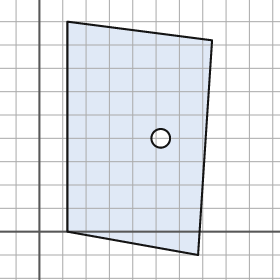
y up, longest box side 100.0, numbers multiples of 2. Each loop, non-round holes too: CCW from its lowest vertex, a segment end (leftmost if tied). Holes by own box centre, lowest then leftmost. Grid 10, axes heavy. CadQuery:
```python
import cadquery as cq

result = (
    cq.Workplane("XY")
    .moveTo(68.0, -10.0)
    .lineTo(74.0, 82.0)
    .lineTo(12.0, 90.0)
    .lineTo(12.0, 0.0)
    .close()
    .moveTo(52.0, 40.0)
    .circle(4.0)
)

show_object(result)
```